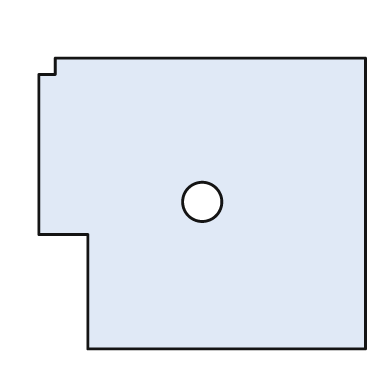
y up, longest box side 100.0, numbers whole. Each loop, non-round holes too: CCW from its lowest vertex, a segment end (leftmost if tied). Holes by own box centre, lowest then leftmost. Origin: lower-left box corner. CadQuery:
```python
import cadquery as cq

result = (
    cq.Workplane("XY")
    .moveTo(15.0, 0.0)
    .lineTo(100.0, 0.0)
    .lineTo(100.0, 89.0)
    .lineTo(5.0, 89.0)
    .lineTo(5.0, 84.0)
    .lineTo(0.0, 84.0)
    .lineTo(0.0, 35.0)
    .lineTo(15.0, 35.0)
    .close()
    .moveTo(50.0, 45.0)
    .circle(6.0)
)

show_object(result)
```